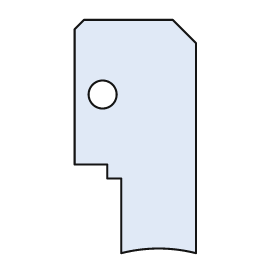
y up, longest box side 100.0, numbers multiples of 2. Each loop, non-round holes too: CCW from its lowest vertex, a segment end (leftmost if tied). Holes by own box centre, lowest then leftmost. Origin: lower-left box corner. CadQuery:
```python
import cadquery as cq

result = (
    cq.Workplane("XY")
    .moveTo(20.0, 0.0)
    .threePointArc((36.0, 2.0), (52.0, 0.0))
    .lineTo(52.0, 90.0)
    .lineTo(42.0, 100.0)
    .lineTo(4.0, 100.0)
    .lineTo(0.0, 96.0)
    .lineTo(0.0, 38.0)
    .lineTo(14.0, 38.0)
    .lineTo(14.0, 32.0)
    .lineTo(20.0, 32.0)
    .close()
    .moveTo(12.0, 68.0)
    .circle(6.0)
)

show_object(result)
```